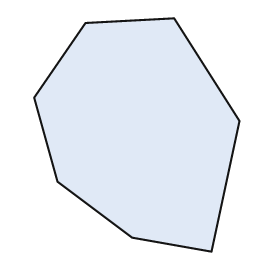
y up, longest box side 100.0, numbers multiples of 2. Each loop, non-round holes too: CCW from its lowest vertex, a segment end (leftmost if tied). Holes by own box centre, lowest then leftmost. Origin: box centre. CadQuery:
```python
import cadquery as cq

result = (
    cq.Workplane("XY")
    .moveTo(32.0, -50.0)
    .lineTo(44.0, 6.0)
    .lineTo(16.0, 50.0)
    .lineTo(-22.0, 48.0)
    .lineTo(-44.0, 16.0)
    .lineTo(-34.0, -20.0)
    .lineTo(-2.0, -44.0)
    .close()
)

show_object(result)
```